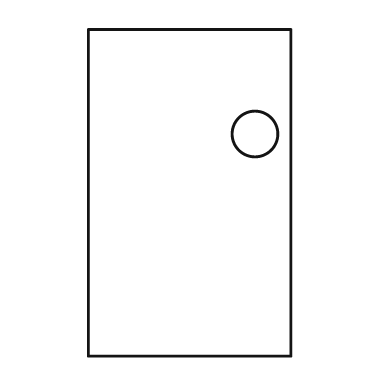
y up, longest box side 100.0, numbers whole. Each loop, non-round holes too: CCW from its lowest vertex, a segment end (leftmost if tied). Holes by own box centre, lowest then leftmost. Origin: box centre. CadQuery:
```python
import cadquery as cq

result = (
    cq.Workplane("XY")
    .moveTo(-31.0, -50.0)
    .lineTo(31.0, -50.0)
    .lineTo(31.0, 50.0)
    .lineTo(-31.0, 50.0)
    .close()
    .moveTo(20.0, 18.0)
    .circle(7.0)
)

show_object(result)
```